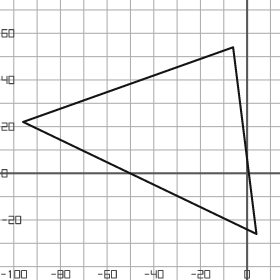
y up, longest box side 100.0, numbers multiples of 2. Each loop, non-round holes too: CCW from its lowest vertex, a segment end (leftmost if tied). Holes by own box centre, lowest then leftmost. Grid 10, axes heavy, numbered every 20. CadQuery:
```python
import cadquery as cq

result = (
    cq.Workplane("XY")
    .moveTo(4.0, -26.0)
    .lineTo(-6.0, 54.0)
    .lineTo(-96.0, 22.0)
    .close()
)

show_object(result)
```